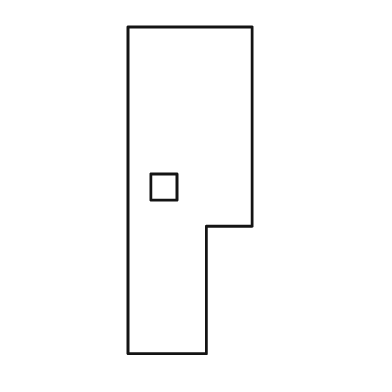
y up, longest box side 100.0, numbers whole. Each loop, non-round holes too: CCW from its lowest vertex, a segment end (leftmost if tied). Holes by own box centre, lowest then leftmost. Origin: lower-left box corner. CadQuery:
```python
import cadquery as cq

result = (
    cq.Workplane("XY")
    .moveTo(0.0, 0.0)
    .lineTo(24.0, 0.0)
    .lineTo(24.0, 39.0)
    .lineTo(38.0, 39.0)
    .lineTo(38.0, 100.0)
    .lineTo(0.0, 100.0)
    .close()
    .moveTo(7.0, 47.0)
    .lineTo(15.0, 47.0)
    .lineTo(15.0, 55.0)
    .lineTo(7.0, 55.0)
    .close()
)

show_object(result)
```